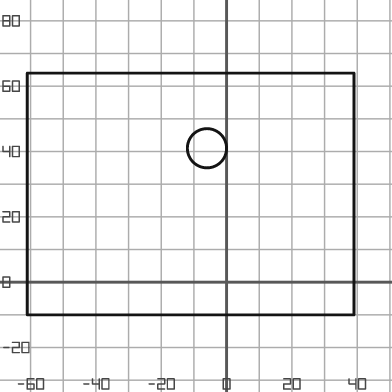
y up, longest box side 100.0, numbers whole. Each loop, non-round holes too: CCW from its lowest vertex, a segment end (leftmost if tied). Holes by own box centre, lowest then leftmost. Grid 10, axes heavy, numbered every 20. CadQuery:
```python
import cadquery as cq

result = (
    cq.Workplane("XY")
    .moveTo(-61.0, -10.0)
    .lineTo(39.0, -10.0)
    .lineTo(39.0, 64.0)
    .lineTo(-61.0, 64.0)
    .close()
    .moveTo(-6.0, 41.0)
    .circle(6.0)
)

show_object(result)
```